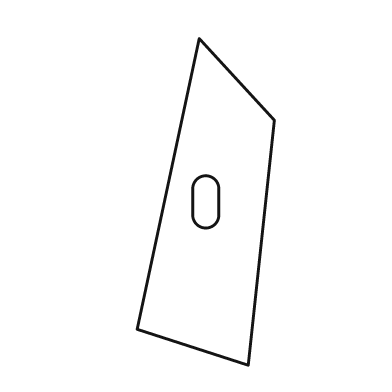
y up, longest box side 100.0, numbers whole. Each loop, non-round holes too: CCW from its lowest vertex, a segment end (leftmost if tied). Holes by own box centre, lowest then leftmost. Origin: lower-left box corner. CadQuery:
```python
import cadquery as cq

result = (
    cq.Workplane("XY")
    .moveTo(34.0, 0.0)
    .lineTo(42.0, 75.0)
    .lineTo(19.0, 100.0)
    .lineTo(0.0, 11.0)
    .close()
    .moveTo(17.0, 46.0)
    .threePointArc((21.0, 42.0), (25.0, 46.0))
    .lineTo(25.0, 54.0)
    .threePointArc((21.0, 58.0), (17.0, 54.0))
    .close()
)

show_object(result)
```